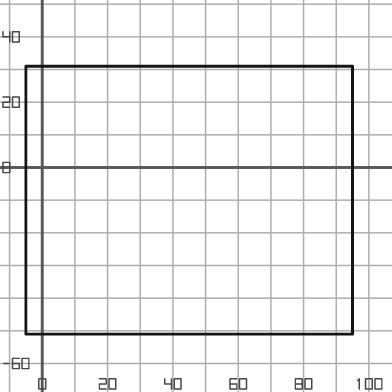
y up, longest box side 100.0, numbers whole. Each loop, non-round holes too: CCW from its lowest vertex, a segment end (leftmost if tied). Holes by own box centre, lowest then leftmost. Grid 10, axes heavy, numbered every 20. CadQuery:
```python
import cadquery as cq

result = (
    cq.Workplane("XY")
    .moveTo(-5.0, -51.0)
    .lineTo(95.0, -51.0)
    .lineTo(95.0, 31.0)
    .lineTo(-5.0, 31.0)
    .close()
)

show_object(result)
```